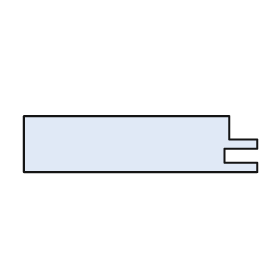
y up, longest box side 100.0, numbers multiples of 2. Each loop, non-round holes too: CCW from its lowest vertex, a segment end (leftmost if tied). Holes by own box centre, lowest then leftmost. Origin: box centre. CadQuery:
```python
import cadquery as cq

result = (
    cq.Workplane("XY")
    .moveTo(-50.0, -12.0)
    .lineTo(50.0, -12.0)
    .lineTo(50.0, -8.0)
    .lineTo(36.0, -8.0)
    .lineTo(36.0, -2.0)
    .lineTo(50.0, -2.0)
    .lineTo(50.0, 2.0)
    .lineTo(38.0, 2.0)
    .lineTo(38.0, 12.0)
    .lineTo(-50.0, 12.0)
    .close()
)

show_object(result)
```